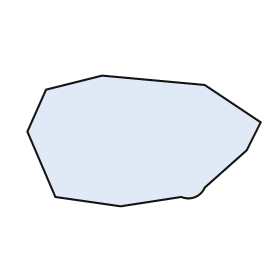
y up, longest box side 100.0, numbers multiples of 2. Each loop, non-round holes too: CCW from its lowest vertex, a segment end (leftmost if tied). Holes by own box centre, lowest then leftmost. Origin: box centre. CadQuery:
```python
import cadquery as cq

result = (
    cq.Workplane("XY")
    .moveTo(-10.0, -28.0)
    .lineTo(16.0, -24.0)
    .threePointArc((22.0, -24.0), (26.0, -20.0))
    .lineTo(44.0, -4.0)
    .lineTo(50.0, 8.0)
    .lineTo(26.0, 24.0)
    .lineTo(-18.0, 28.0)
    .lineTo(-42.0, 22.0)
    .lineTo(-50.0, 4.0)
    .lineTo(-38.0, -24.0)
    .close()
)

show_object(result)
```